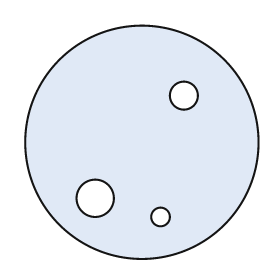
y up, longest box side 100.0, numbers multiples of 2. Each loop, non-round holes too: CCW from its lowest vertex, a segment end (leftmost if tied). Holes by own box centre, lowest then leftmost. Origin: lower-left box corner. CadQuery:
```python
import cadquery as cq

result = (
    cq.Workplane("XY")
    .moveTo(50.0, 50.0)
    .circle(50.0)
    .moveTo(58.0, 18.0)
    .circle(4.0)
    .moveTo(30.0, 26.0)
    .circle(8.0)
    .moveTo(68.0, 70.0)
    .circle(6.0)
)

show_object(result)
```